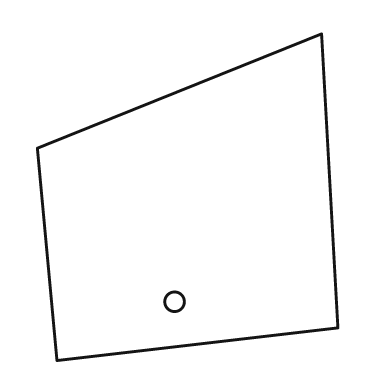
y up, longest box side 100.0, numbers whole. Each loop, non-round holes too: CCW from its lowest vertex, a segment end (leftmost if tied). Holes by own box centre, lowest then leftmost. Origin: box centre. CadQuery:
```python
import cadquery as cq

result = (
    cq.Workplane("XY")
    .moveTo(-40.0, -50.0)
    .lineTo(46.0, -40.0)
    .lineTo(41.0, 50.0)
    .lineTo(-46.0, 15.0)
    .close()
    .moveTo(-4.0, -32.0)
    .circle(3.0)
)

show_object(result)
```